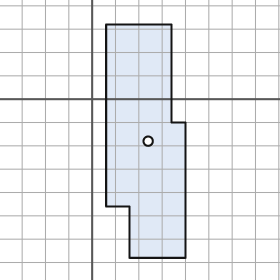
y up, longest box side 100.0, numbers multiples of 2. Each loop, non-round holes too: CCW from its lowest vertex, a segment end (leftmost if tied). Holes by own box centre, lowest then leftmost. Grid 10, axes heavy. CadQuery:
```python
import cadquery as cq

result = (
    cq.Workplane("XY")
    .moveTo(16.0, -68.0)
    .lineTo(40.0, -68.0)
    .lineTo(40.0, -10.0)
    .lineTo(34.0, -10.0)
    .lineTo(34.0, 32.0)
    .lineTo(6.0, 32.0)
    .lineTo(6.0, -46.0)
    .lineTo(16.0, -46.0)
    .close()
    .moveTo(24.0, -18.0)
    .circle(2.0)
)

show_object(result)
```